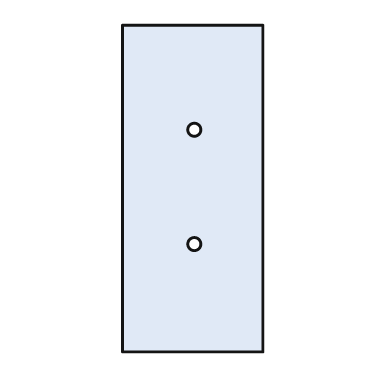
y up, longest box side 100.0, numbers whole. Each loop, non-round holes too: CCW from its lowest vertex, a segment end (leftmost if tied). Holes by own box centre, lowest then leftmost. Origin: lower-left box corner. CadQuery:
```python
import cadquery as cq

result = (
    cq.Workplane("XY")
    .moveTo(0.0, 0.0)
    .lineTo(43.0, 0.0)
    .lineTo(43.0, 100.0)
    .lineTo(0.0, 100.0)
    .close()
    .moveTo(22.0, 33.0)
    .circle(2.0)
    .moveTo(22.0, 68.0)
    .circle(2.0)
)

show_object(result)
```